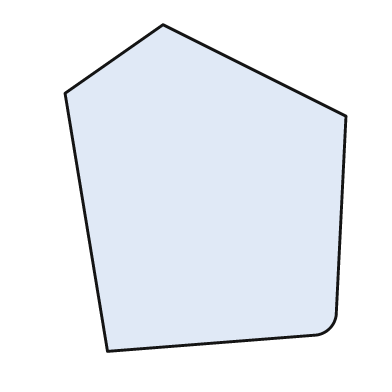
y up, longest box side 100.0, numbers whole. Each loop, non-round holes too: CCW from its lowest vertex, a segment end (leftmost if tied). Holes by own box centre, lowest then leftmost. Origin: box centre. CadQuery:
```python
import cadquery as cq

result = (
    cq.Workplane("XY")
    .moveTo(-30.0, -50.0)
    .lineTo(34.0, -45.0)
    .threePointArc((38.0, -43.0), (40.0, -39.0))
    .lineTo(43.0, 22.0)
    .lineTo(-13.0, 50.0)
    .lineTo(-43.0, 29.0)
    .close()
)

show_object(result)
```